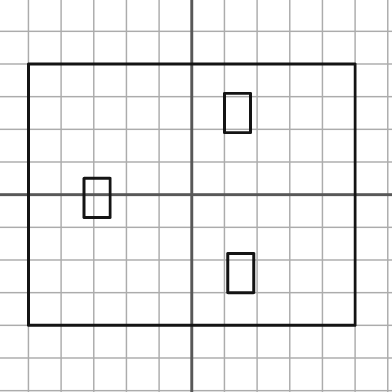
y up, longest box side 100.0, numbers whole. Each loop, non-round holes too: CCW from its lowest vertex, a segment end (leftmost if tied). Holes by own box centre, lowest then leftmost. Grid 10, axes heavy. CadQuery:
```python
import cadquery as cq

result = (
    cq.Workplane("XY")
    .moveTo(-50.0, -40.0)
    .lineTo(50.0, -40.0)
    .lineTo(50.0, 40.0)
    .lineTo(-50.0, 40.0)
    .close()
    .moveTo(11.0, -30.0)
    .lineTo(19.0, -30.0)
    .lineTo(19.0, -18.0)
    .lineTo(11.0, -18.0)
    .close()
    .moveTo(-33.0, -7.0)
    .lineTo(-25.0, -7.0)
    .lineTo(-25.0, 5.0)
    .lineTo(-33.0, 5.0)
    .close()
    .moveTo(10.0, 19.0)
    .lineTo(18.0, 19.0)
    .lineTo(18.0, 31.0)
    .lineTo(10.0, 31.0)
    .close()
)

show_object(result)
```